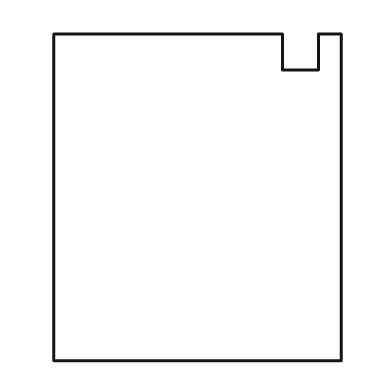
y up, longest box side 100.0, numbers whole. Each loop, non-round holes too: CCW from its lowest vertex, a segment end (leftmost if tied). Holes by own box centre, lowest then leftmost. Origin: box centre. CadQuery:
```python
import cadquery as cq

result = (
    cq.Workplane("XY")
    .moveTo(-44.0, -50.0)
    .lineTo(44.0, -50.0)
    .lineTo(44.0, 50.0)
    .lineTo(37.0, 50.0)
    .lineTo(37.0, 39.0)
    .lineTo(26.0, 39.0)
    .lineTo(26.0, 50.0)
    .lineTo(-44.0, 50.0)
    .close()
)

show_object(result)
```